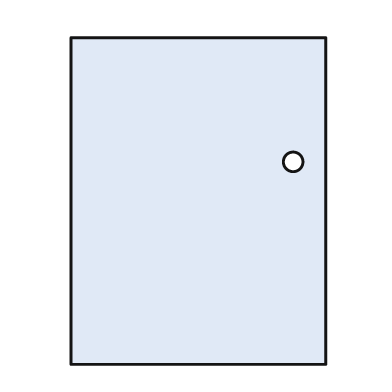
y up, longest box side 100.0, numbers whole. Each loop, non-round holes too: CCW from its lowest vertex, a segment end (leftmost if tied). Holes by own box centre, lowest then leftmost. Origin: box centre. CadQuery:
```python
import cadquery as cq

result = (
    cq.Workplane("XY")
    .moveTo(-39.0, -50.0)
    .lineTo(39.0, -50.0)
    .lineTo(39.0, 50.0)
    .lineTo(-39.0, 50.0)
    .close()
    .moveTo(29.0, 12.0)
    .circle(3.0)
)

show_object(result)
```